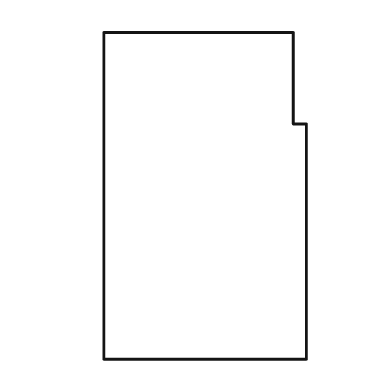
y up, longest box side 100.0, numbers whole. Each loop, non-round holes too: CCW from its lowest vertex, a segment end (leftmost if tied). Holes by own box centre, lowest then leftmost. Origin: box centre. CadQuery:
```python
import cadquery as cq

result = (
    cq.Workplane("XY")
    .moveTo(-31.0, -50.0)
    .lineTo(31.0, -50.0)
    .lineTo(31.0, 22.0)
    .lineTo(27.0, 22.0)
    .lineTo(27.0, 50.0)
    .lineTo(-31.0, 50.0)
    .close()
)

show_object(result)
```